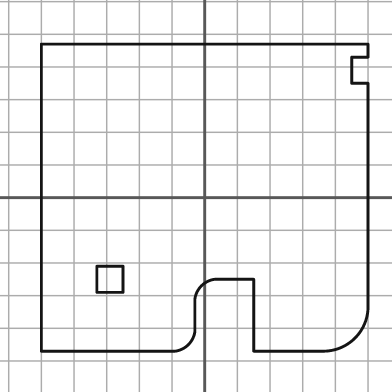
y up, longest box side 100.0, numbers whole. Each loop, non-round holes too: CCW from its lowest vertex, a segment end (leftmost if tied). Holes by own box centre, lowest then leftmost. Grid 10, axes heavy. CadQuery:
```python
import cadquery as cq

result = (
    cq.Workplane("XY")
    .moveTo(-50.0, -47.0)
    .lineTo(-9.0, -47.0)
    .threePointArc((-5.0, -45.0), (-3.0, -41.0))
    .lineTo(-3.0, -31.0)
    .threePointArc((-1.0, -27.0), (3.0, -25.0))
    .lineTo(15.0, -25.0)
    .lineTo(15.0, -47.0)
    .lineTo(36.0, -47.0)
    .threePointArc((46.0, -43.0), (50.0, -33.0))
    .lineTo(50.0, 35.0)
    .lineTo(45.0, 35.0)
    .lineTo(45.0, 43.0)
    .lineTo(50.0, 43.0)
    .lineTo(50.0, 47.0)
    .lineTo(-50.0, 47.0)
    .close()
    .moveTo(-33.0, -29.0)
    .lineTo(-25.0, -29.0)
    .lineTo(-25.0, -21.0)
    .lineTo(-33.0, -21.0)
    .close()
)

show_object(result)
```